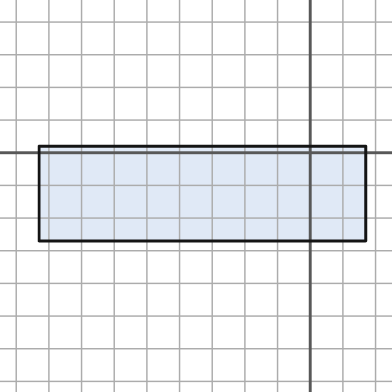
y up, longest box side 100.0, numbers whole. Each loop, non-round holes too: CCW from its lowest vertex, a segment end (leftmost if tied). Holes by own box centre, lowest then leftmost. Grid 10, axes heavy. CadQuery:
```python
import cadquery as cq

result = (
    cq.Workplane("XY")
    .moveTo(-83.0, -27.0)
    .lineTo(17.0, -27.0)
    .lineTo(17.0, 2.0)
    .lineTo(-83.0, 2.0)
    .close()
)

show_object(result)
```